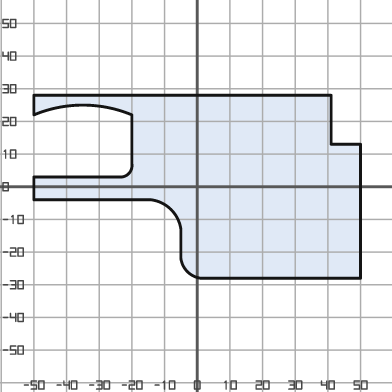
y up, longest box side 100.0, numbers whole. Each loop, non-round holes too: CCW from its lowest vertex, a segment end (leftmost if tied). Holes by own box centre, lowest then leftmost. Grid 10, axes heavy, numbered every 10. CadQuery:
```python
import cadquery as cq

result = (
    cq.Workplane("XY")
    .moveTo(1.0, -28.0)
    .lineTo(50.0, -28.0)
    .lineTo(50.0, 13.0)
    .lineTo(41.0, 13.0)
    .lineTo(41.0, 28.0)
    .lineTo(-50.0, 28.0)
    .lineTo(-50.0, 22.0)
    .threePointArc((-35.0, 25.0), (-20.0, 22.0))
    .lineTo(-20.0, 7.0)
    .threePointArc((-21.0, 4.0), (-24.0, 3.0))
    .lineTo(-50.0, 3.0)
    .lineTo(-50.0, -4.0)
    .lineTo(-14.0, -4.0)
    .threePointArc((-8.0, -7.0), (-5.0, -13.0))
    .lineTo(-5.0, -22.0)
    .threePointArc((-3.0, -26.0), (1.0, -28.0))
    .close()
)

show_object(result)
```